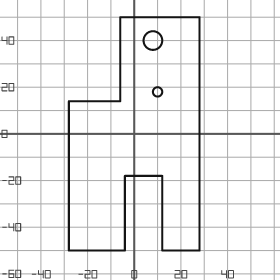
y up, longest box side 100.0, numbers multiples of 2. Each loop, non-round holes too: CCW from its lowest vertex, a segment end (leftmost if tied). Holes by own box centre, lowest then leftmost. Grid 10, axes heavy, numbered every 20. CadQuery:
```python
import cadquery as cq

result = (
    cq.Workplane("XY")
    .moveTo(-28.0, -50.0)
    .lineTo(-4.0, -50.0)
    .lineTo(-4.0, -18.0)
    .lineTo(12.0, -18.0)
    .lineTo(12.0, -50.0)
    .lineTo(28.0, -50.0)
    .lineTo(28.0, 50.0)
    .lineTo(-6.0, 50.0)
    .lineTo(-6.0, 14.0)
    .lineTo(-28.0, 14.0)
    .close()
    .moveTo(10.0, 18.0)
    .circle(2.0)
    .moveTo(8.0, 40.0)
    .circle(4.0)
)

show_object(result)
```